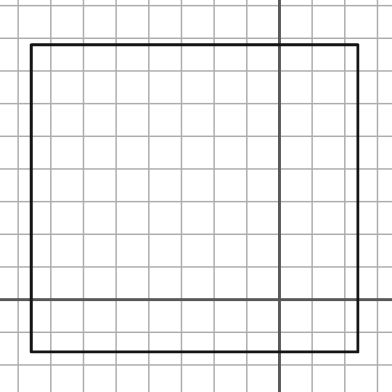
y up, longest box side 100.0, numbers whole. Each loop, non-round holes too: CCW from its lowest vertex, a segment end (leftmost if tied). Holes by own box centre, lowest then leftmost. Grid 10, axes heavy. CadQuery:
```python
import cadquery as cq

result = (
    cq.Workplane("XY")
    .moveTo(-76.0, -16.0)
    .lineTo(24.0, -16.0)
    .lineTo(24.0, 78.0)
    .lineTo(-76.0, 78.0)
    .close()
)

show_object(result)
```